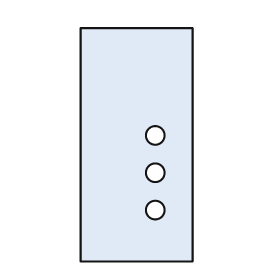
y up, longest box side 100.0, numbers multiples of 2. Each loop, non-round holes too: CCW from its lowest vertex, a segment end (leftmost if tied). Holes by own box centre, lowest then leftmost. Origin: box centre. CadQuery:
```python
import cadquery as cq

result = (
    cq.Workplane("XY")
    .moveTo(-24.0, -50.0)
    .lineTo(24.0, -50.0)
    .lineTo(24.0, 50.0)
    .lineTo(-24.0, 50.0)
    .close()
    .moveTo(8.0, -28.0)
    .circle(4.0)
    .moveTo(8.0, -12.0)
    .circle(4.0)
    .moveTo(8.0, 4.0)
    .circle(4.0)
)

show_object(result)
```